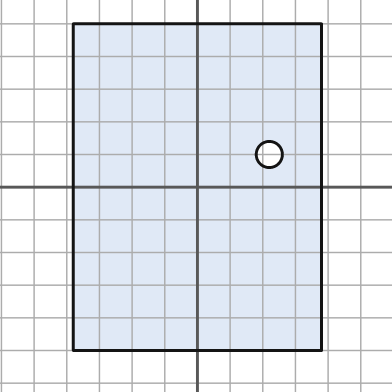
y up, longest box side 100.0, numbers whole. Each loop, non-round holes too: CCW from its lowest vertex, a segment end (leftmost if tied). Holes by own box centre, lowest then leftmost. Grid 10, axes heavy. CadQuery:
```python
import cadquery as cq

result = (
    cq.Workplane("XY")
    .moveTo(-38.0, -50.0)
    .lineTo(38.0, -50.0)
    .lineTo(38.0, 50.0)
    .lineTo(-38.0, 50.0)
    .close()
    .moveTo(22.0, 10.0)
    .circle(4.0)
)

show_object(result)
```